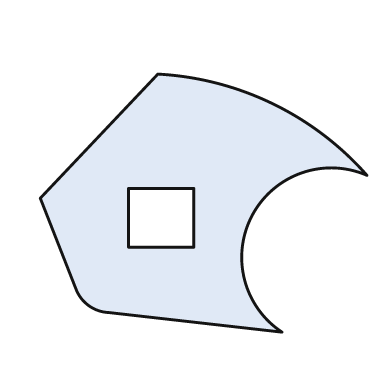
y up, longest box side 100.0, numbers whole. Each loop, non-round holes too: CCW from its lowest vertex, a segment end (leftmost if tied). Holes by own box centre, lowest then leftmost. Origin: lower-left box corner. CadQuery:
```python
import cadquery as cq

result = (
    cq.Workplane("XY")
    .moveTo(74.0, 0.0)
    .threePointArc((65.0, 36.0), (100.0, 48.0))
    .threePointArc((71.0, 70.0), (36.0, 79.0))
    .lineTo(0.0, 41.0)
    .lineTo(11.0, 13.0)
    .threePointArc((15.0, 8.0), (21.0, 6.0))
    .close()
    .moveTo(27.0, 26.0)
    .lineTo(47.0, 26.0)
    .lineTo(47.0, 44.0)
    .lineTo(27.0, 44.0)
    .close()
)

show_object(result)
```